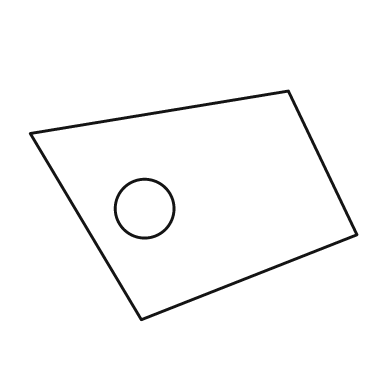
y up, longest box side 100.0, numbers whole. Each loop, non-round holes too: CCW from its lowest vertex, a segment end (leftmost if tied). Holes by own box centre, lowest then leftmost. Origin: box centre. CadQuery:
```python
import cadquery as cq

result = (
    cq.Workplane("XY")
    .moveTo(-16.0, -35.0)
    .lineTo(50.0, -9.0)
    .lineTo(29.0, 35.0)
    .lineTo(-50.0, 22.0)
    .close()
    .moveTo(-15.0, -1.0)
    .circle(9.0)
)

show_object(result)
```